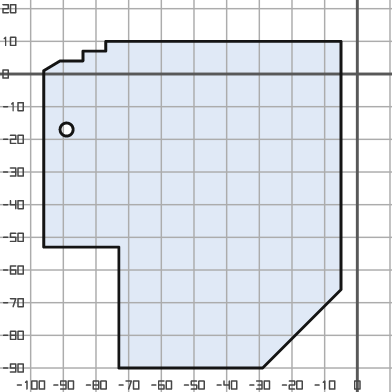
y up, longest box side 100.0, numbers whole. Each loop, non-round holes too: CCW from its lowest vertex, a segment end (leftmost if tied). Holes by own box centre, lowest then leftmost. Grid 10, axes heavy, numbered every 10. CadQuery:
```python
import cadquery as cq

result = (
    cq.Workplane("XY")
    .moveTo(-73.0, -90.0)
    .lineTo(-29.0, -90.0)
    .lineTo(-5.0, -66.0)
    .lineTo(-5.0, 10.0)
    .lineTo(-77.0, 10.0)
    .lineTo(-77.0, 7.0)
    .lineTo(-84.0, 7.0)
    .lineTo(-84.0, 4.0)
    .lineTo(-91.0, 4.0)
    .lineTo(-96.0, 1.0)
    .lineTo(-96.0, -53.0)
    .lineTo(-73.0, -53.0)
    .close()
    .moveTo(-89.0, -17.0)
    .circle(2.0)
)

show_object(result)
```